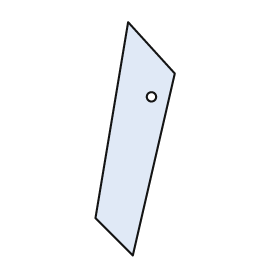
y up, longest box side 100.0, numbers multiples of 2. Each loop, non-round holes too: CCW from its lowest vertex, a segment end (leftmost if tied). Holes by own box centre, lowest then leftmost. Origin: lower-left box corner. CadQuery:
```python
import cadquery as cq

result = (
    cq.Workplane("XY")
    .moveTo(16.0, 0.0)
    .lineTo(34.0, 78.0)
    .lineTo(14.0, 100.0)
    .lineTo(0.0, 16.0)
    .close()
    .moveTo(24.0, 68.0)
    .circle(2.0)
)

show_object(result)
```